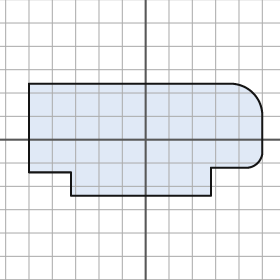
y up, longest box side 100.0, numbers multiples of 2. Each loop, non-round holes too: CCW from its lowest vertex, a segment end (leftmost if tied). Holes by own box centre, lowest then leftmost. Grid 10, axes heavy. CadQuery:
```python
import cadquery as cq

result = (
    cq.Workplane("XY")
    .moveTo(-32.0, -24.0)
    .lineTo(28.0, -24.0)
    .lineTo(28.0, -12.0)
    .lineTo(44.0, -12.0)
    .threePointArc((48.0, -10.0), (50.0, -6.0))
    .lineTo(50.0, 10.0)
    .threePointArc((46.0, 20.0), (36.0, 24.0))
    .lineTo(-50.0, 24.0)
    .lineTo(-50.0, -14.0)
    .lineTo(-32.0, -14.0)
    .close()
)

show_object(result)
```